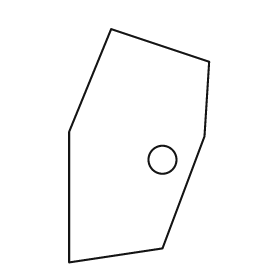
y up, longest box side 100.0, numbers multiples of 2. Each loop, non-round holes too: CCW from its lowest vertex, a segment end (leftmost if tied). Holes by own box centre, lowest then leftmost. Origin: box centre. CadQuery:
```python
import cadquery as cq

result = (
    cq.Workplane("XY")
    .moveTo(-30.0, -50.0)
    .lineTo(10.0, -44.0)
    .lineTo(28.0, 4.0)
    .lineTo(30.0, 36.0)
    .lineTo(-12.0, 50.0)
    .lineTo(-30.0, 6.0)
    .close()
    .moveTo(10.0, -6.0)
    .circle(6.0)
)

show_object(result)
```